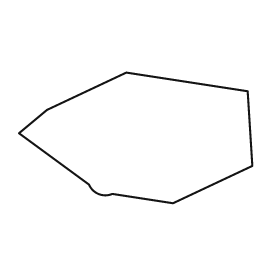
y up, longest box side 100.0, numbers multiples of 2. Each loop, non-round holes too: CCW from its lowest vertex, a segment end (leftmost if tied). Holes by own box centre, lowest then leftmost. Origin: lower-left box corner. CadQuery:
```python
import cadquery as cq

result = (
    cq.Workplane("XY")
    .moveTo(66.0, 0.0)
    .lineTo(100.0, 16.0)
    .lineTo(98.0, 48.0)
    .lineTo(46.0, 56.0)
    .lineTo(12.0, 40.0)
    .lineTo(0.0, 30.0)
    .lineTo(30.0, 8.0)
    .threePointArc((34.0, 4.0), (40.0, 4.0))
    .close()
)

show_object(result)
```